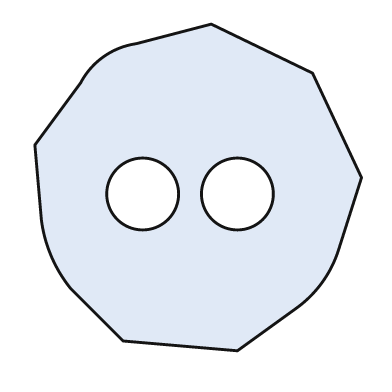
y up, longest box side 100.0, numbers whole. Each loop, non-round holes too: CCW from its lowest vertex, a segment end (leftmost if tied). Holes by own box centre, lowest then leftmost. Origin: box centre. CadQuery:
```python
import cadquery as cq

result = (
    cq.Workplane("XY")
    .moveTo(12.0, -50.0)
    .lineTo(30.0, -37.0)
    .threePointArc((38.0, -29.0), (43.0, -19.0))
    .lineTo(50.0, 3.0)
    .lineTo(35.0, 35.0)
    .lineTo(4.0, 50.0)
    .lineTo(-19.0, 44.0)
    .threePointArc((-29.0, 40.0), (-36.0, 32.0))
    .lineTo(-50.0, 13.0)
    .lineTo(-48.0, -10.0)
    .threePointArc((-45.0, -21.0), (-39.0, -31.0))
    .lineTo(-23.0, -47.0)
    .close()
    .moveTo(-17.0, -2.0)
    .circle(11.0)
    .moveTo(12.0, -2.0)
    .circle(11.0)
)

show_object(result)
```